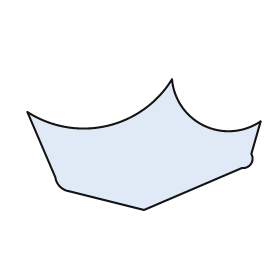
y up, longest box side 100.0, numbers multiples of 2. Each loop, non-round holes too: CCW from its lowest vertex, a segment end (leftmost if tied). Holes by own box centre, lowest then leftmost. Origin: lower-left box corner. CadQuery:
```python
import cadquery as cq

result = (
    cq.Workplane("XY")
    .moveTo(50.0, 0.0)
    .lineTo(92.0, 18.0)
    .threePointArc((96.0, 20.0), (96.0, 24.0))
    .lineTo(100.0, 38.0)
    .threePointArc((76.0, 36.0), (62.0, 56.0))
    .threePointArc((34.0, 36.0), (0.0, 42.0))
    .lineTo(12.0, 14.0)
    .threePointArc((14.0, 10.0), (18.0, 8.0))
    .close()
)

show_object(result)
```